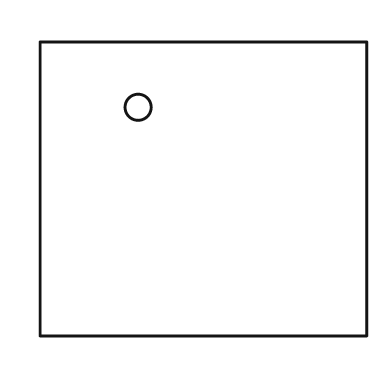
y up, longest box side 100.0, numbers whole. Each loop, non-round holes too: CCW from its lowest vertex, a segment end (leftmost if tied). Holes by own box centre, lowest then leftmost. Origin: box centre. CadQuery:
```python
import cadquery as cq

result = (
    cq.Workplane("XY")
    .moveTo(-50.0, -45.0)
    .lineTo(50.0, -45.0)
    .lineTo(50.0, 45.0)
    .lineTo(-50.0, 45.0)
    .close()
    .moveTo(-20.0, 25.0)
    .circle(4.0)
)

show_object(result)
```